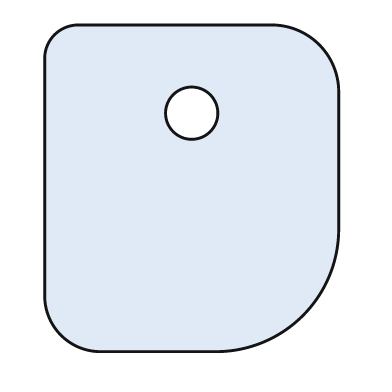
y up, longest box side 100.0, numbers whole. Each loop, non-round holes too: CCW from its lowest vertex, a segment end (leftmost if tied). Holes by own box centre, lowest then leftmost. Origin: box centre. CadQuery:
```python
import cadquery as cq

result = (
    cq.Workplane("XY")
    .moveTo(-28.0, -50.0)
    .lineTo(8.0, -50.0)
    .threePointArc((34.0, -39.0), (45.0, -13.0))
    .lineTo(45.0, 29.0)
    .threePointArc((39.0, 44.0), (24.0, 50.0))
    .lineTo(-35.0, 50.0)
    .threePointArc((-42.0, 47.0), (-45.0, 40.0))
    .lineTo(-45.0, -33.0)
    .threePointArc((-40.0, -45.0), (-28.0, -50.0))
    .close()
    .moveTo(0.0, 23.0)
    .circle(8.0)
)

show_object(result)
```